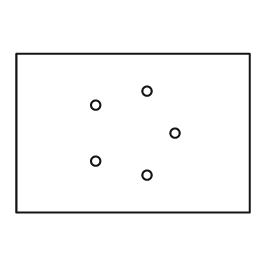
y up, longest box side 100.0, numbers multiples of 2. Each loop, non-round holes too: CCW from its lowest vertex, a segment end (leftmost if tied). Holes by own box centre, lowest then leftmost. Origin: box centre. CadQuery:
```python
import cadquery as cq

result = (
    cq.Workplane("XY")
    .moveTo(-50.0, -34.0)
    .lineTo(50.0, -34.0)
    .lineTo(50.0, 34.0)
    .lineTo(-50.0, 34.0)
    .close()
    .moveTo(6.0, -18.0)
    .circle(2.0)
    .moveTo(-16.0, -12.0)
    .circle(2.0)
    .moveTo(18.0, 0.0)
    .circle(2.0)
    .moveTo(-16.0, 12.0)
    .circle(2.0)
    .moveTo(6.0, 18.0)
    .circle(2.0)
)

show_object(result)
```